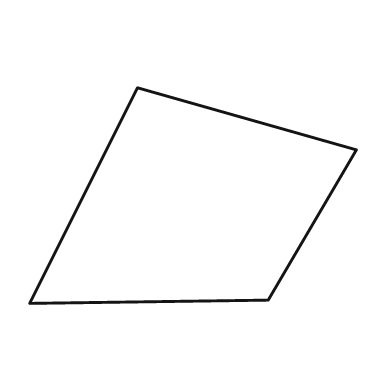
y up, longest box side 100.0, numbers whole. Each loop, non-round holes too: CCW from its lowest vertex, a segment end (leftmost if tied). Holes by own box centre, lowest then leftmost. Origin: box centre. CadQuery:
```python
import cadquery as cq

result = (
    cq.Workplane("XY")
    .moveTo(-50.0, -33.0)
    .lineTo(23.0, -32.0)
    .lineTo(50.0, 14.0)
    .lineTo(-17.0, 33.0)
    .close()
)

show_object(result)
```